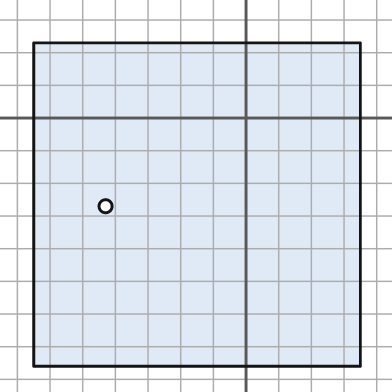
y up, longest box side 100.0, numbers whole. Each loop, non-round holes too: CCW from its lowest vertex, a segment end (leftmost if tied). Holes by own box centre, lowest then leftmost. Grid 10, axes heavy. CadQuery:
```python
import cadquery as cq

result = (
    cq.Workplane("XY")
    .moveTo(-65.0, -76.0)
    .lineTo(35.0, -76.0)
    .lineTo(35.0, 23.0)
    .lineTo(-65.0, 23.0)
    .close()
    .moveTo(-43.0, -27.0)
    .circle(2.0)
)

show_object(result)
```